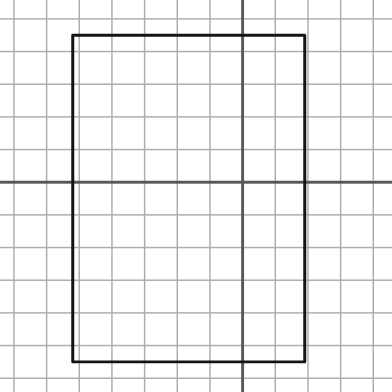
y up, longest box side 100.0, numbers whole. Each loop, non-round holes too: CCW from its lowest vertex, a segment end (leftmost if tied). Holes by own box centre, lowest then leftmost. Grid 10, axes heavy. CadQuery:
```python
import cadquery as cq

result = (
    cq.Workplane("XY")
    .moveTo(-52.0, -55.0)
    .lineTo(19.0, -55.0)
    .lineTo(19.0, 45.0)
    .lineTo(-52.0, 45.0)
    .close()
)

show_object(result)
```